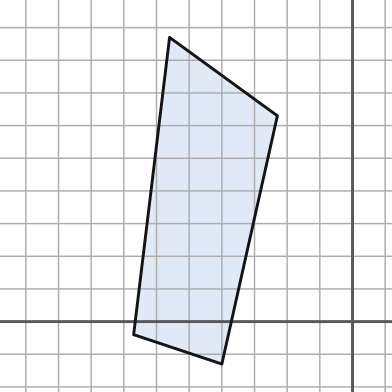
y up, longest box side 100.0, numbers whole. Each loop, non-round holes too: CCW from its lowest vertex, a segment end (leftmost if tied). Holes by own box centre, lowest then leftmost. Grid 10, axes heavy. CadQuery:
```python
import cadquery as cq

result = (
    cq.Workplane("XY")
    .moveTo(-40.0, -13.0)
    .lineTo(-23.0, 63.0)
    .lineTo(-56.0, 87.0)
    .lineTo(-67.0, -4.0)
    .close()
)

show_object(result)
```